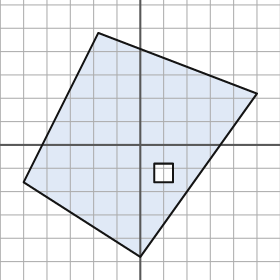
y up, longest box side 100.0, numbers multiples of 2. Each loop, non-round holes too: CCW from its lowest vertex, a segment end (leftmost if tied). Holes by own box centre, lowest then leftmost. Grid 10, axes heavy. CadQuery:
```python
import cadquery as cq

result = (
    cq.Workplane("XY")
    .moveTo(0.0, -48.0)
    .lineTo(50.0, 22.0)
    .lineTo(-18.0, 48.0)
    .lineTo(-50.0, -16.0)
    .close()
    .moveTo(6.0, -16.0)
    .lineTo(14.0, -16.0)
    .lineTo(14.0, -8.0)
    .lineTo(6.0, -8.0)
    .close()
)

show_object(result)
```